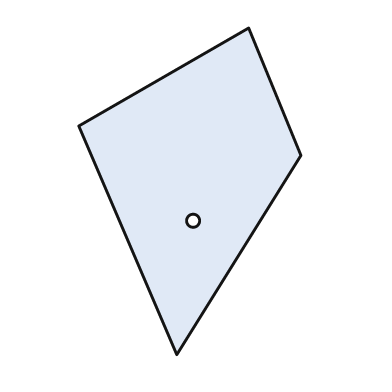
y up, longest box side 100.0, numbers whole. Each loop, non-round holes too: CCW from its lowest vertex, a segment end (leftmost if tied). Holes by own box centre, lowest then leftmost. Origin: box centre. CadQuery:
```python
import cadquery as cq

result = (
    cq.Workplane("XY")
    .moveTo(-4.0, -50.0)
    .lineTo(34.0, 11.0)
    .lineTo(18.0, 50.0)
    .lineTo(-34.0, 20.0)
    .close()
    .moveTo(1.0, -9.0)
    .circle(2.0)
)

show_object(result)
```